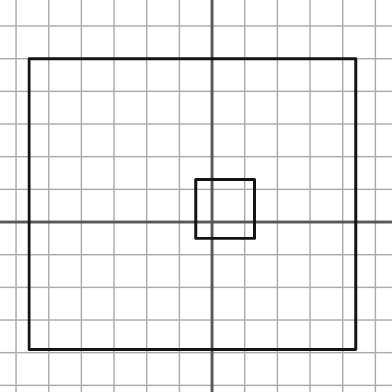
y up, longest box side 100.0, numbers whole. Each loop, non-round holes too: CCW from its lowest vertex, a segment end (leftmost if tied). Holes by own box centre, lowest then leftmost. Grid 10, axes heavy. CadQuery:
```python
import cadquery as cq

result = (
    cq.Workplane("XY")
    .moveTo(-56.0, -39.0)
    .lineTo(44.0, -39.0)
    .lineTo(44.0, 50.0)
    .lineTo(-56.0, 50.0)
    .close()
    .moveTo(-5.0, -5.0)
    .lineTo(13.0, -5.0)
    .lineTo(13.0, 13.0)
    .lineTo(-5.0, 13.0)
    .close()
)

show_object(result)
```